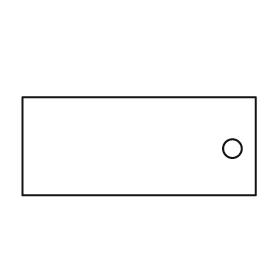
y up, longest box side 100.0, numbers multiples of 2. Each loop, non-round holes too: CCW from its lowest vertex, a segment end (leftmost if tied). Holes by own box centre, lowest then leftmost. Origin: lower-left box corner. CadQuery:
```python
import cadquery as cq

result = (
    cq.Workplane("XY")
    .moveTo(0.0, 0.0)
    .lineTo(100.0, 0.0)
    .lineTo(100.0, 42.0)
    .lineTo(0.0, 42.0)
    .close()
    .moveTo(90.0, 20.0)
    .circle(4.0)
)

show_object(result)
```